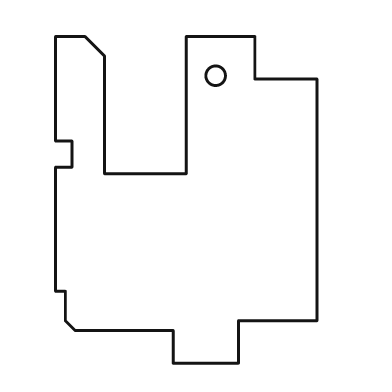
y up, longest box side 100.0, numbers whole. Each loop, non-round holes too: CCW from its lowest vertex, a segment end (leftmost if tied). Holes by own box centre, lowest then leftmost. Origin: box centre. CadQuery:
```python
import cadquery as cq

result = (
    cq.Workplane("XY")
    .moveTo(-4.0, -50.0)
    .lineTo(16.0, -50.0)
    .lineTo(16.0, -37.0)
    .lineTo(40.0, -37.0)
    .lineTo(40.0, 37.0)
    .lineTo(21.0, 37.0)
    .lineTo(21.0, 50.0)
    .lineTo(0.0, 50.0)
    .lineTo(0.0, 8.0)
    .lineTo(-25.0, 8.0)
    .lineTo(-25.0, 44.0)
    .lineTo(-31.0, 50.0)
    .lineTo(-40.0, 50.0)
    .lineTo(-40.0, 18.0)
    .lineTo(-35.0, 18.0)
    .lineTo(-35.0, 10.0)
    .lineTo(-40.0, 10.0)
    .lineTo(-40.0, -28.0)
    .lineTo(-37.0, -28.0)
    .lineTo(-37.0, -37.0)
    .lineTo(-34.0, -40.0)
    .lineTo(-4.0, -40.0)
    .close()
    .moveTo(9.0, 38.0)
    .circle(3.0)
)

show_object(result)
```